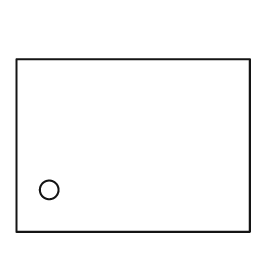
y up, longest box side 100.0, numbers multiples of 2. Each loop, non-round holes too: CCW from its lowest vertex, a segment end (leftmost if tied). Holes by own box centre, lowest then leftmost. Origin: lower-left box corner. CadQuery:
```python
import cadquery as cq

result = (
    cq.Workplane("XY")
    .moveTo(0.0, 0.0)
    .lineTo(100.0, 0.0)
    .lineTo(100.0, 74.0)
    .lineTo(0.0, 74.0)
    .close()
    .moveTo(14.0, 18.0)
    .circle(4.0)
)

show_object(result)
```